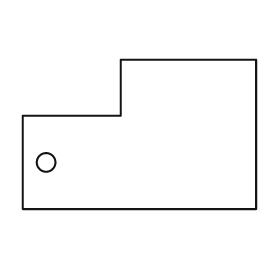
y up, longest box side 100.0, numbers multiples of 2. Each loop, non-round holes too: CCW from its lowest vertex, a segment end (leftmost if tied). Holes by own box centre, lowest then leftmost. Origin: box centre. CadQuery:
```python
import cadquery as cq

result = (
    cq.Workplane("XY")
    .moveTo(-50.0, -32.0)
    .lineTo(50.0, -32.0)
    .lineTo(50.0, 32.0)
    .lineTo(-8.0, 32.0)
    .lineTo(-8.0, 8.0)
    .lineTo(-50.0, 8.0)
    .close()
    .moveTo(-40.0, -12.0)
    .circle(4.0)
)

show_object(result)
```